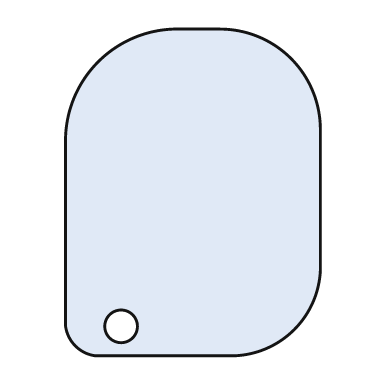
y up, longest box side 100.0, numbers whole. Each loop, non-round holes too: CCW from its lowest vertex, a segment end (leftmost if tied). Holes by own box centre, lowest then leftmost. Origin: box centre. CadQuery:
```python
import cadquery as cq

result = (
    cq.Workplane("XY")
    .moveTo(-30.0, -50.0)
    .lineTo(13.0, -50.0)
    .threePointArc((31.0, -42.0), (39.0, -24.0))
    .lineTo(39.0, 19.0)
    .threePointArc((30.0, 41.0), (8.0, 50.0))
    .lineTo(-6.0, 50.0)
    .threePointArc((-29.0, 40.0), (-39.0, 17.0))
    .lineTo(-39.0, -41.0)
    .threePointArc((-36.0, -47.0), (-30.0, -50.0))
    .close()
    .moveTo(-22.0, -41.0)
    .circle(5.0)
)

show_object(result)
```